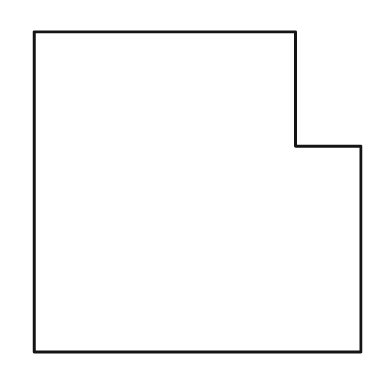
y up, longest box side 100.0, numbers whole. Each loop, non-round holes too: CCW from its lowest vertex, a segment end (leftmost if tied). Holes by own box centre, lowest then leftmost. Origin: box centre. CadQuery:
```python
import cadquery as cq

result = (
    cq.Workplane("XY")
    .moveTo(-50.0, -49.0)
    .lineTo(50.0, -49.0)
    .lineTo(50.0, 14.0)
    .lineTo(30.0, 14.0)
    .lineTo(30.0, 49.0)
    .lineTo(-50.0, 49.0)
    .close()
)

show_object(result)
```